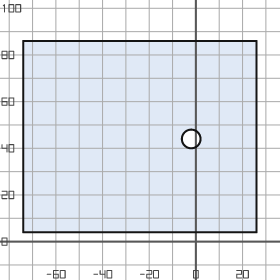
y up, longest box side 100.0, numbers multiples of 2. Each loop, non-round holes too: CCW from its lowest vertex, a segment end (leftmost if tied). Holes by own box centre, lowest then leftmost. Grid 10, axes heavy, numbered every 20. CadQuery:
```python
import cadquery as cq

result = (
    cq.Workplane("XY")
    .moveTo(-74.0, 4.0)
    .lineTo(26.0, 4.0)
    .lineTo(26.0, 86.0)
    .lineTo(-74.0, 86.0)
    .close()
    .moveTo(-2.0, 44.0)
    .circle(4.0)
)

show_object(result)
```